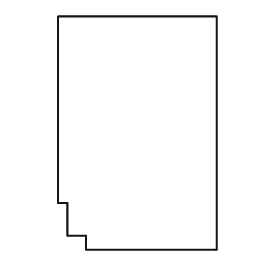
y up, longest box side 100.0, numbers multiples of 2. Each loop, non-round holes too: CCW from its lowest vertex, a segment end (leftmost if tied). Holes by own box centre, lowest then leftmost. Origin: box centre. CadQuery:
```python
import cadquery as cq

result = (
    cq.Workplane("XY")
    .moveTo(-22.0, -50.0)
    .lineTo(34.0, -50.0)
    .lineTo(34.0, 50.0)
    .lineTo(-34.0, 50.0)
    .lineTo(-34.0, -30.0)
    .lineTo(-30.0, -30.0)
    .lineTo(-30.0, -44.0)
    .lineTo(-22.0, -44.0)
    .close()
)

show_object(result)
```